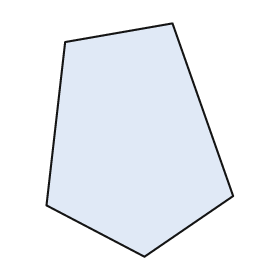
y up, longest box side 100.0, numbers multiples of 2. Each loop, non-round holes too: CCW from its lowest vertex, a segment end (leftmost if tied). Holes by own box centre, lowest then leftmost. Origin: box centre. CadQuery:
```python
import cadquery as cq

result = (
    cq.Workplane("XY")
    .moveTo(2.0, -50.0)
    .lineTo(40.0, -24.0)
    .lineTo(14.0, 50.0)
    .lineTo(-32.0, 42.0)
    .lineTo(-40.0, -28.0)
    .close()
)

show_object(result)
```